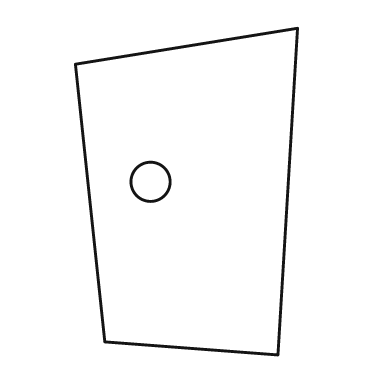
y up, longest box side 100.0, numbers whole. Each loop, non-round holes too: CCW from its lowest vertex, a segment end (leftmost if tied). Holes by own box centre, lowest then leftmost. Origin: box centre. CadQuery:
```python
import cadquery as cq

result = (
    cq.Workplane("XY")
    .moveTo(28.0, -50.0)
    .lineTo(34.0, 50.0)
    .lineTo(-34.0, 39.0)
    .lineTo(-25.0, -46.0)
    .close()
    .moveTo(-11.0, 3.0)
    .circle(6.0)
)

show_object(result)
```